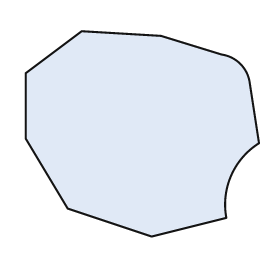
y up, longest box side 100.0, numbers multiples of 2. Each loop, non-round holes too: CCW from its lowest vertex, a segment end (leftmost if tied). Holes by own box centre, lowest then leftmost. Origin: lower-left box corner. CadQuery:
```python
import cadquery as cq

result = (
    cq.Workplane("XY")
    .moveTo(54.0, 0.0)
    .lineTo(86.0, 8.0)
    .threePointArc((88.0, 26.0), (100.0, 40.0))
    .lineTo(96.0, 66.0)
    .threePointArc((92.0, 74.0), (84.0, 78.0))
    .lineTo(58.0, 86.0)
    .lineTo(24.0, 88.0)
    .lineTo(0.0, 70.0)
    .lineTo(0.0, 42.0)
    .lineTo(18.0, 12.0)
    .close()
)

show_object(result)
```